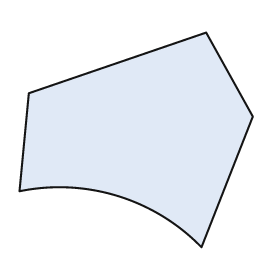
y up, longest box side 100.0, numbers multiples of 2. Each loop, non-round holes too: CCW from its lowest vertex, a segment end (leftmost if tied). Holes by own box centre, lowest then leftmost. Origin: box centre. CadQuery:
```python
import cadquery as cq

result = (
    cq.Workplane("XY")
    .moveTo(28.0, -46.0)
    .lineTo(50.0, 10.0)
    .lineTo(30.0, 46.0)
    .lineTo(-46.0, 20.0)
    .lineTo(-50.0, -22.0)
    .threePointArc((-8.0, -24.0), (28.0, -46.0))
    .close()
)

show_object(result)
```